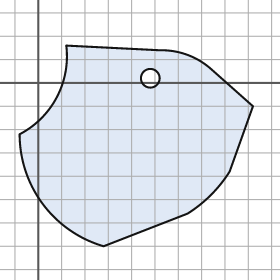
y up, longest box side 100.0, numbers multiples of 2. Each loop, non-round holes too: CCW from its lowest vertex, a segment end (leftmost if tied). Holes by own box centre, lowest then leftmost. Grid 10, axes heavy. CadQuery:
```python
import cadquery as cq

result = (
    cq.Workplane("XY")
    .moveTo(28.0, -70.0)
    .lineTo(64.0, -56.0)
    .threePointArc((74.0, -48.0), (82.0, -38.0))
    .lineTo(92.0, -10.0)
    .lineTo(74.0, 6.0)
    .threePointArc((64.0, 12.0), (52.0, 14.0))
    .lineTo(12.0, 16.0)
    .threePointArc((8.0, -6.0), (-8.0, -22.0))
    .threePointArc((2.0, -52.0), (28.0, -70.0))
    .close()
    .moveTo(48.0, 2.0)
    .circle(4.0)
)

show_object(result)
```